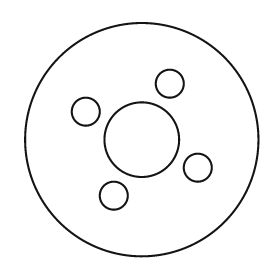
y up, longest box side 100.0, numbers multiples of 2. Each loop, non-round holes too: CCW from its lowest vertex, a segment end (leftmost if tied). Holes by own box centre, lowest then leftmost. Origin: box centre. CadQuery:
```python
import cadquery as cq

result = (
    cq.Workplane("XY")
    .moveTo(0.0, 0.0)
    .circle(50.0)
    .moveTo(-12.0, -24.0)
    .circle(6.0)
    .moveTo(24.0, -12.0)
    .circle(6.0)
    .moveTo(0.0, 0.0)
    .circle(16.0)
    .moveTo(-24.0, 12.0)
    .circle(6.0)
    .moveTo(12.0, 24.0)
    .circle(6.0)
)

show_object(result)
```